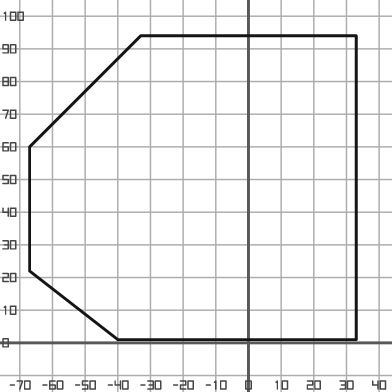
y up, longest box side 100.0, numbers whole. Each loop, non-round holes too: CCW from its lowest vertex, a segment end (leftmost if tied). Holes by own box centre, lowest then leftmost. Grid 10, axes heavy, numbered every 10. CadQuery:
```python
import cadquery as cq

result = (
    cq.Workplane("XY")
    .moveTo(-40.0, 1.0)
    .lineTo(33.0, 1.0)
    .lineTo(33.0, 94.0)
    .lineTo(-33.0, 94.0)
    .lineTo(-67.0, 60.0)
    .lineTo(-67.0, 22.0)
    .close()
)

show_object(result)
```